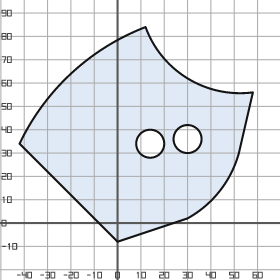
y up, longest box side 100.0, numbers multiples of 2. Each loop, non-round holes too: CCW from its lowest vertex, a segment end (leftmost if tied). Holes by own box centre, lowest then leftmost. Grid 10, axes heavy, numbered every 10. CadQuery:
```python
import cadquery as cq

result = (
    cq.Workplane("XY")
    .moveTo(0.0, -8.0)
    .lineTo(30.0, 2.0)
    .threePointArc((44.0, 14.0), (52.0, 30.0))
    .lineTo(58.0, 56.0)
    .threePointArc((30.0, 62.0), (12.0, 84.0))
    .threePointArc((-20.0, 64.0), (-42.0, 34.0))
    .close()
    .moveTo(14.0, 34.0)
    .circle(6.0)
    .moveTo(30.0, 36.0)
    .circle(6.0)
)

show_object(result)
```